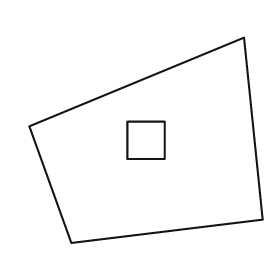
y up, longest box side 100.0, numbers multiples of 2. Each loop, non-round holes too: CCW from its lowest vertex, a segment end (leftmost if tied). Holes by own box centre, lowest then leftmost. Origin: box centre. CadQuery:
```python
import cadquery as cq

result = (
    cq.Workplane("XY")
    .moveTo(-32.0, -44.0)
    .lineTo(50.0, -34.0)
    .lineTo(42.0, 44.0)
    .lineTo(-50.0, 6.0)
    .close()
    .moveTo(-8.0, -8.0)
    .lineTo(8.0, -8.0)
    .lineTo(8.0, 8.0)
    .lineTo(-8.0, 8.0)
    .close()
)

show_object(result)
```